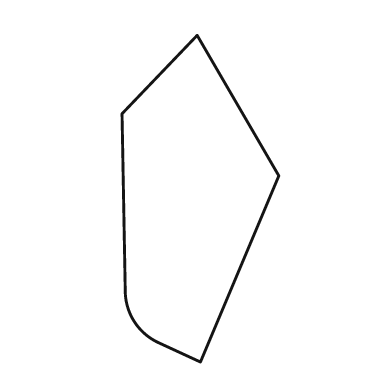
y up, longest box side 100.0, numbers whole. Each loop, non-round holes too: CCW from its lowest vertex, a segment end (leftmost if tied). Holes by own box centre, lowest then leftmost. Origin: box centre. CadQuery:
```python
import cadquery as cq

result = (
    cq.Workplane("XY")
    .moveTo(0.0, -50.0)
    .lineTo(24.0, 7.0)
    .lineTo(-1.0, 50.0)
    .lineTo(-24.0, 26.0)
    .lineTo(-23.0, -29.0)
    .threePointArc((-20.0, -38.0), (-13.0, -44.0))
    .close()
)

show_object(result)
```